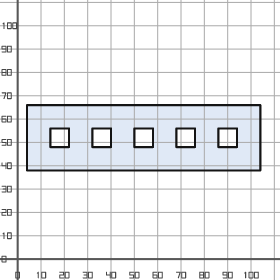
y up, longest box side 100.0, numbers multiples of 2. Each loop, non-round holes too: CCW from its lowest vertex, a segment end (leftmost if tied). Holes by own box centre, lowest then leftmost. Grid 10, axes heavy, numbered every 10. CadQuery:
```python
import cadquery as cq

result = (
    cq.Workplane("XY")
    .moveTo(4.0, 38.0)
    .lineTo(104.0, 38.0)
    .lineTo(104.0, 66.0)
    .lineTo(4.0, 66.0)
    .close()
    .moveTo(14.0, 48.0)
    .lineTo(22.0, 48.0)
    .lineTo(22.0, 56.0)
    .lineTo(14.0, 56.0)
    .close()
    .moveTo(32.0, 48.0)
    .lineTo(40.0, 48.0)
    .lineTo(40.0, 56.0)
    .lineTo(32.0, 56.0)
    .close()
    .moveTo(50.0, 48.0)
    .lineTo(58.0, 48.0)
    .lineTo(58.0, 56.0)
    .lineTo(50.0, 56.0)
    .close()
    .moveTo(68.0, 48.0)
    .lineTo(76.0, 48.0)
    .lineTo(76.0, 56.0)
    .lineTo(68.0, 56.0)
    .close()
    .moveTo(86.0, 48.0)
    .lineTo(94.0, 48.0)
    .lineTo(94.0, 56.0)
    .lineTo(86.0, 56.0)
    .close()
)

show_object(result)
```